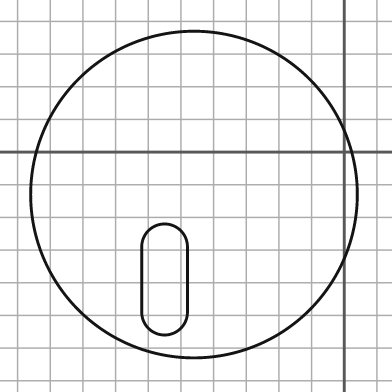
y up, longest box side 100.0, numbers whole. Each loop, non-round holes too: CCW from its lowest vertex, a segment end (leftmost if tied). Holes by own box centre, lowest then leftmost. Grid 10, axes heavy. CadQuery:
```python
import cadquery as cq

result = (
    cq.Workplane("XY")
    .moveTo(-46.0, -13.0)
    .circle(50.0)
    .moveTo(-62.0, -49.0)
    .threePointArc((-55.0, -56.0), (-48.0, -49.0))
    .lineTo(-48.0, -29.0)
    .threePointArc((-55.0, -22.0), (-62.0, -29.0))
    .close()
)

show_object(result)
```